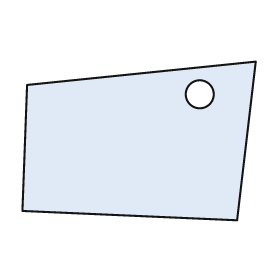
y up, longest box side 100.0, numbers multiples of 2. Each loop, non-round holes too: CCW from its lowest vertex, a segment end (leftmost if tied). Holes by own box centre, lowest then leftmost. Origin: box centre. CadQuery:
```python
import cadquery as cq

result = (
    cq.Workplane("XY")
    .moveTo(42.0, -34.0)
    .lineTo(50.0, 34.0)
    .lineTo(-48.0, 24.0)
    .lineTo(-50.0, -30.0)
    .close()
    .moveTo(26.0, 20.0)
    .circle(6.0)
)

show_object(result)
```